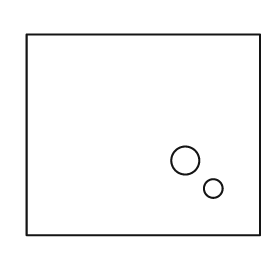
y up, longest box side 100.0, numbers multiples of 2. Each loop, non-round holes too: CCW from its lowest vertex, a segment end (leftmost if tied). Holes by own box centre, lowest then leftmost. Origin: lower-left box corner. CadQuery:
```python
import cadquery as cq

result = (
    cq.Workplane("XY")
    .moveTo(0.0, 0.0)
    .lineTo(100.0, 0.0)
    .lineTo(100.0, 86.0)
    .lineTo(0.0, 86.0)
    .close()
    .moveTo(80.0, 20.0)
    .circle(4.0)
    .moveTo(68.0, 32.0)
    .circle(6.0)
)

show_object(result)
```